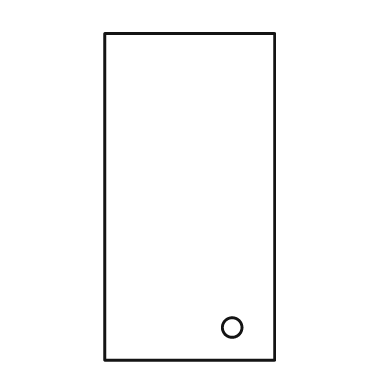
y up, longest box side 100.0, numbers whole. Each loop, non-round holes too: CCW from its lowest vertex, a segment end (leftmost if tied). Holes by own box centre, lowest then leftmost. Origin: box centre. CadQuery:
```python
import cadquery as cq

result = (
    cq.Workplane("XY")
    .moveTo(-26.0, -50.0)
    .lineTo(26.0, -50.0)
    .lineTo(26.0, 50.0)
    .lineTo(-26.0, 50.0)
    .close()
    .moveTo(13.0, -40.0)
    .circle(3.0)
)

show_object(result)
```